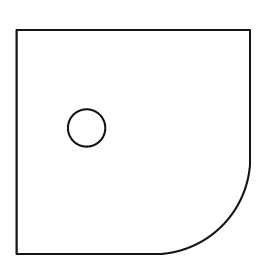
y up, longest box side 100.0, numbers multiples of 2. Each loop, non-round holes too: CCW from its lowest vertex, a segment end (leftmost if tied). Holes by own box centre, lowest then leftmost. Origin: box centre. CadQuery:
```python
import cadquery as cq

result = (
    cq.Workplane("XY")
    .moveTo(-50.0, -48.0)
    .lineTo(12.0, -48.0)
    .threePointArc((38.0, -36.0), (50.0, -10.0))
    .lineTo(50.0, 48.0)
    .lineTo(-50.0, 48.0)
    .close()
    .moveTo(-20.0, 6.0)
    .circle(8.0)
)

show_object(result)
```